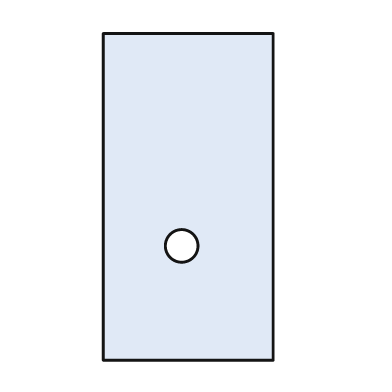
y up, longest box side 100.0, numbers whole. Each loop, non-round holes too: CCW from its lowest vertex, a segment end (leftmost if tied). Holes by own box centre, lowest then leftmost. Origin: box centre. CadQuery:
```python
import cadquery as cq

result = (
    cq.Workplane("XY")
    .moveTo(-26.0, -50.0)
    .lineTo(26.0, -50.0)
    .lineTo(26.0, 50.0)
    .lineTo(-26.0, 50.0)
    .close()
    .moveTo(-2.0, -15.0)
    .circle(5.0)
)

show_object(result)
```